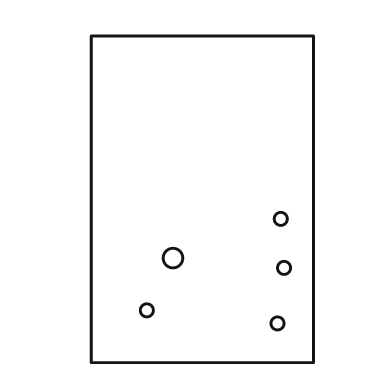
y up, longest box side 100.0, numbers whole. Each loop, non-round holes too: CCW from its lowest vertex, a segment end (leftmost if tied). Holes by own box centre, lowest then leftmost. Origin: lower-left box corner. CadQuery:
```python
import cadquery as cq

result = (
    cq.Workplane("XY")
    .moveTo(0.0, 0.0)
    .lineTo(68.0, 0.0)
    .lineTo(68.0, 100.0)
    .lineTo(0.0, 100.0)
    .close()
    .moveTo(57.0, 12.0)
    .circle(2.0)
    .moveTo(17.0, 16.0)
    .circle(2.0)
    .moveTo(59.0, 29.0)
    .circle(2.0)
    .moveTo(25.0, 32.0)
    .circle(3.0)
    .moveTo(58.0, 44.0)
    .circle(2.0)
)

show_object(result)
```